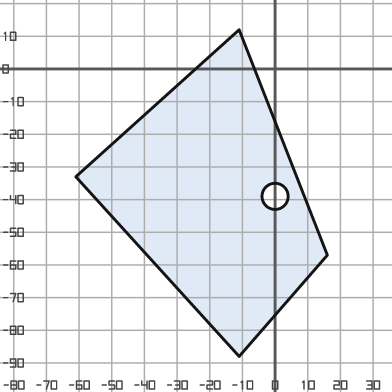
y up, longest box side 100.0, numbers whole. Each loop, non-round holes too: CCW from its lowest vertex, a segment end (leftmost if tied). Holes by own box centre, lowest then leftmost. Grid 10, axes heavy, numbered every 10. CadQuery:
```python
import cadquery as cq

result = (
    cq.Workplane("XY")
    .moveTo(-11.0, -88.0)
    .lineTo(16.0, -57.0)
    .lineTo(-11.0, 12.0)
    .lineTo(-61.0, -33.0)
    .close()
    .moveTo(0.0, -39.0)
    .circle(4.0)
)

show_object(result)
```